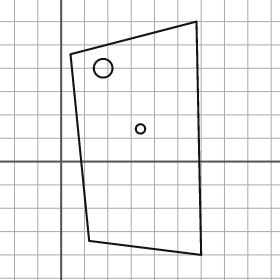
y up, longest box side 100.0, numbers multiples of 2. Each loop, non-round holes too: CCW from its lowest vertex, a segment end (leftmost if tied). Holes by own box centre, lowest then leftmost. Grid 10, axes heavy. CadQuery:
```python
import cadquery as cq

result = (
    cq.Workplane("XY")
    .moveTo(60.0, -40.0)
    .lineTo(58.0, 60.0)
    .lineTo(4.0, 46.0)
    .lineTo(12.0, -34.0)
    .close()
    .moveTo(34.0, 14.0)
    .circle(2.0)
    .moveTo(18.0, 40.0)
    .circle(4.0)
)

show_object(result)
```